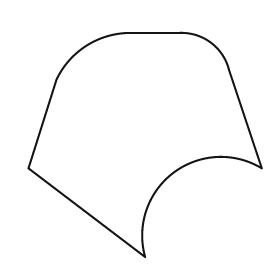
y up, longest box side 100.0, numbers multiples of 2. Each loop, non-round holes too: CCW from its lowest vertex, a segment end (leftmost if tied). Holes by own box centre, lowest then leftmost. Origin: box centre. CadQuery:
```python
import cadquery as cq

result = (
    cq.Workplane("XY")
    .moveTo(0.0, -48.0)
    .threePointArc((12.0, -12.0), (50.0, -10.0))
    .lineTo(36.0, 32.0)
    .threePointArc((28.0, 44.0), (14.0, 48.0))
    .lineTo(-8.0, 48.0)
    .threePointArc((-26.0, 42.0), (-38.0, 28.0))
    .lineTo(-50.0, -10.0)
    .close()
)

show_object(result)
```